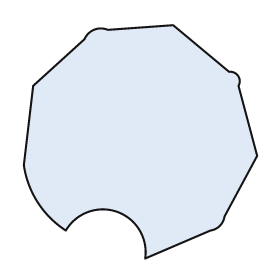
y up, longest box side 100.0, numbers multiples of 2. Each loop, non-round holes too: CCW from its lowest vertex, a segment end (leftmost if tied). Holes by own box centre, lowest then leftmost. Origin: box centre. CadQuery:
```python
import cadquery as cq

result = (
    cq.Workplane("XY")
    .moveTo(2.0, -50.0)
    .lineTo(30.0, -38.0)
    .threePointArc((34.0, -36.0), (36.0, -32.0))
    .lineTo(50.0, -6.0)
    .lineTo(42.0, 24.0)
    .threePointArc((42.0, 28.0), (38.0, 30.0))
    .lineTo(14.0, 50.0)
    .lineTo(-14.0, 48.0)
    .threePointArc((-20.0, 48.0), (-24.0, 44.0))
    .lineTo(-46.0, 24.0)
    .lineTo(-50.0, -10.0)
    .threePointArc((-44.0, -26.0), (-32.0, -38.0))
    .threePointArc((-10.0, -30.0), (2.0, -50.0))
    .close()
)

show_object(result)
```